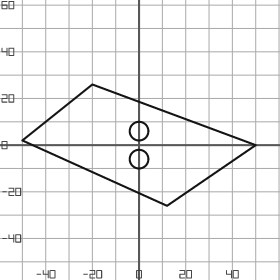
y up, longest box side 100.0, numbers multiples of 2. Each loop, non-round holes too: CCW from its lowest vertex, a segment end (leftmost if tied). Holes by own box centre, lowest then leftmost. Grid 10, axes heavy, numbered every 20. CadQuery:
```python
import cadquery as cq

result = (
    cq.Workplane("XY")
    .moveTo(12.0, -26.0)
    .lineTo(50.0, 0.0)
    .lineTo(-20.0, 26.0)
    .lineTo(-50.0, 2.0)
    .close()
    .moveTo(0.0, -6.0)
    .circle(4.0)
    .moveTo(0.0, 6.0)
    .circle(4.0)
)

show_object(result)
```